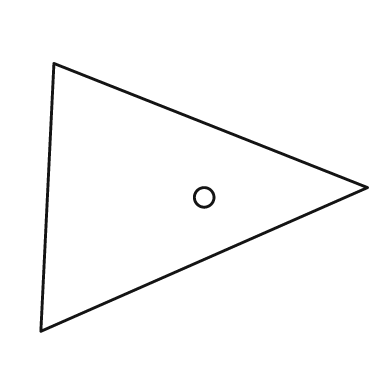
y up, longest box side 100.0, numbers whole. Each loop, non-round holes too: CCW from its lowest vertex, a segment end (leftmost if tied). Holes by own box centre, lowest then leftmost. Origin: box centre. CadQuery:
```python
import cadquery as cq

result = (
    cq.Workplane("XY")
    .moveTo(-50.0, -41.0)
    .lineTo(50.0, 3.0)
    .lineTo(-46.0, 41.0)
    .close()
    .moveTo(0.0, 0.0)
    .circle(3.0)
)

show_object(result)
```